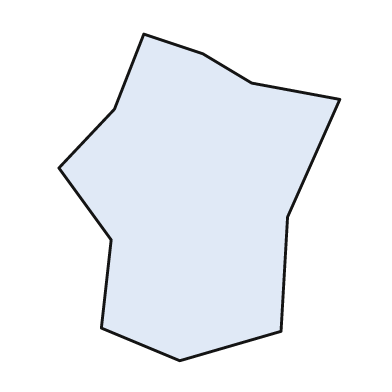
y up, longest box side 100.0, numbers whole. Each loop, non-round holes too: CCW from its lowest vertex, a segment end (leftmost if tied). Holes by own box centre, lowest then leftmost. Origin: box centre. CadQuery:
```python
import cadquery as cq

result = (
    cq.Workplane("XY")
    .moveTo(-6.0, -50.0)
    .lineTo(25.0, -41.0)
    .lineTo(27.0, -6.0)
    .lineTo(43.0, 30.0)
    .lineTo(16.0, 35.0)
    .lineTo(1.0, 44.0)
    .lineTo(-17.0, 50.0)
    .lineTo(-26.0, 27.0)
    .lineTo(-43.0, 9.0)
    .lineTo(-27.0, -13.0)
    .lineTo(-30.0, -40.0)
    .close()
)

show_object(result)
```